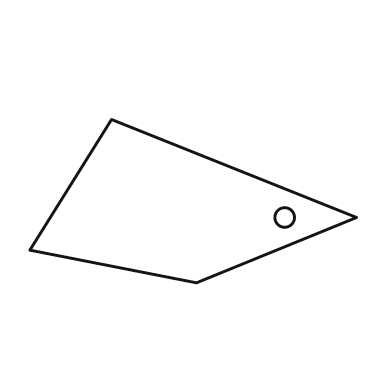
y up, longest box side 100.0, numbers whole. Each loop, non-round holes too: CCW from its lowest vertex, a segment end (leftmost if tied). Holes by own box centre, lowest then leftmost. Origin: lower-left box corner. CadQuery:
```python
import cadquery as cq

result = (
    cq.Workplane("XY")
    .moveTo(51.0, 0.0)
    .lineTo(100.0, 20.0)
    .lineTo(25.0, 50.0)
    .lineTo(0.0, 10.0)
    .close()
    .moveTo(78.0, 20.0)
    .circle(3.0)
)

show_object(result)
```